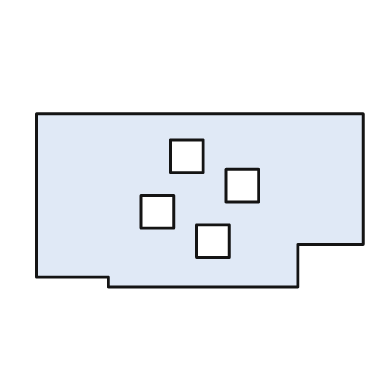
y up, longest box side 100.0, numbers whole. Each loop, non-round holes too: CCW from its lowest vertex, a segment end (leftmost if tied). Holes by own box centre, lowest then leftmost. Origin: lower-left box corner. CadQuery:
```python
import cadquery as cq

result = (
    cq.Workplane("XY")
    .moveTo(22.0, 0.0)
    .lineTo(80.0, 0.0)
    .lineTo(80.0, 13.0)
    .lineTo(100.0, 13.0)
    .lineTo(100.0, 53.0)
    .lineTo(0.0, 53.0)
    .lineTo(0.0, 3.0)
    .lineTo(22.0, 3.0)
    .close()
    .moveTo(49.0, 9.0)
    .lineTo(59.0, 9.0)
    .lineTo(59.0, 19.0)
    .lineTo(49.0, 19.0)
    .close()
    .moveTo(32.0, 18.0)
    .lineTo(42.0, 18.0)
    .lineTo(42.0, 28.0)
    .lineTo(32.0, 28.0)
    .close()
    .moveTo(58.0, 26.0)
    .lineTo(68.0, 26.0)
    .lineTo(68.0, 36.0)
    .lineTo(58.0, 36.0)
    .close()
    .moveTo(41.0, 35.0)
    .lineTo(51.0, 35.0)
    .lineTo(51.0, 45.0)
    .lineTo(41.0, 45.0)
    .close()
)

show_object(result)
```